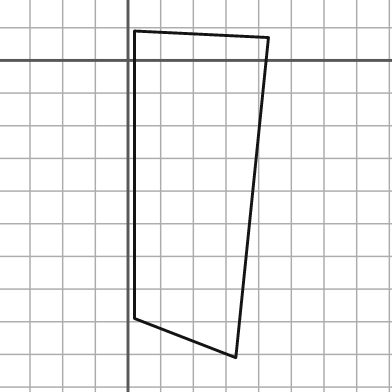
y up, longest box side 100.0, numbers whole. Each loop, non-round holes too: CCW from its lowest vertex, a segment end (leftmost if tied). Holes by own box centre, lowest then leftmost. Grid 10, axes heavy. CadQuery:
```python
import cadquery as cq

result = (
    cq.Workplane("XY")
    .moveTo(33.0, -91.0)
    .lineTo(43.0, 7.0)
    .lineTo(2.0, 9.0)
    .lineTo(2.0, -79.0)
    .close()
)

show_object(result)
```